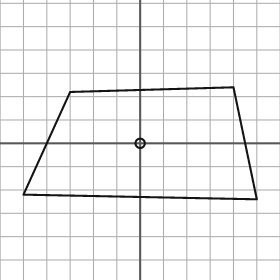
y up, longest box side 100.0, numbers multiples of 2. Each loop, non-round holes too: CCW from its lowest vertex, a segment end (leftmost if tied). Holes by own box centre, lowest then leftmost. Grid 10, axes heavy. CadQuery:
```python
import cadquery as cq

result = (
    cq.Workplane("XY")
    .moveTo(50.0, -24.0)
    .lineTo(40.0, 24.0)
    .lineTo(-30.0, 22.0)
    .lineTo(-50.0, -22.0)
    .close()
    .moveTo(0.0, 0.0)
    .circle(2.0)
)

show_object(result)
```